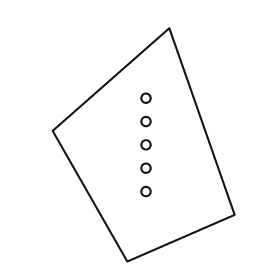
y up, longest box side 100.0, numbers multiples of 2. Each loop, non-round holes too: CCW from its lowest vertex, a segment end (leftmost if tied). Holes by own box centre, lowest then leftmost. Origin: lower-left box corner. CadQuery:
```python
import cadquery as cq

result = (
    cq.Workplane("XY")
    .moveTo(32.0, 0.0)
    .lineTo(78.0, 20.0)
    .lineTo(50.0, 100.0)
    .lineTo(0.0, 56.0)
    .close()
    .moveTo(40.0, 30.0)
    .circle(2.0)
    .moveTo(40.0, 40.0)
    .circle(2.0)
    .moveTo(40.0, 50.0)
    .circle(2.0)
    .moveTo(40.0, 60.0)
    .circle(2.0)
    .moveTo(40.0, 70.0)
    .circle(2.0)
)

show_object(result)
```